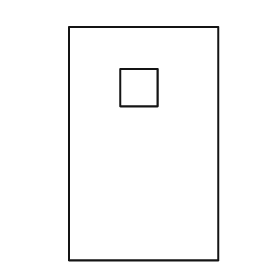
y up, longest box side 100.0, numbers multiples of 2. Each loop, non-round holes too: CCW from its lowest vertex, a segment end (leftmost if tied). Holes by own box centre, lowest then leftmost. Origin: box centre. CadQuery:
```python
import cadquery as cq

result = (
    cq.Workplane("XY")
    .moveTo(-32.0, -50.0)
    .lineTo(32.0, -50.0)
    .lineTo(32.0, 50.0)
    .lineTo(-32.0, 50.0)
    .close()
    .moveTo(-10.0, 16.0)
    .lineTo(6.0, 16.0)
    .lineTo(6.0, 32.0)
    .lineTo(-10.0, 32.0)
    .close()
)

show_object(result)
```